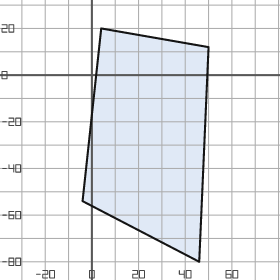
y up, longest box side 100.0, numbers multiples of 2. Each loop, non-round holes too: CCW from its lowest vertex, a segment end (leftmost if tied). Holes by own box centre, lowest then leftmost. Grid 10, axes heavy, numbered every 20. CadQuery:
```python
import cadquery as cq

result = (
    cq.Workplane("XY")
    .moveTo(46.0, -80.0)
    .lineTo(50.0, 12.0)
    .lineTo(4.0, 20.0)
    .lineTo(-4.0, -54.0)
    .close()
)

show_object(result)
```